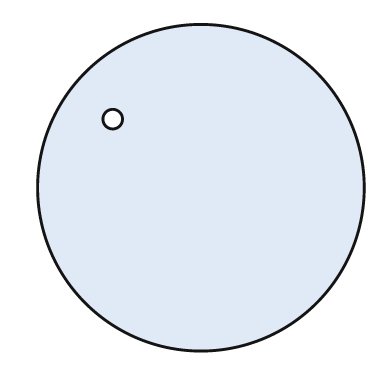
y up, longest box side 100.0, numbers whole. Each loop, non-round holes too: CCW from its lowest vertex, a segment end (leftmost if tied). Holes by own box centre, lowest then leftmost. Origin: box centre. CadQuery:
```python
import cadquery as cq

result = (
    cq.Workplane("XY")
    .moveTo(0.0, 0.0)
    .circle(50.0)
    .moveTo(-27.0, 21.0)
    .circle(3.0)
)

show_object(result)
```